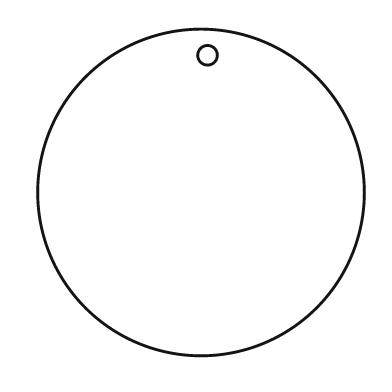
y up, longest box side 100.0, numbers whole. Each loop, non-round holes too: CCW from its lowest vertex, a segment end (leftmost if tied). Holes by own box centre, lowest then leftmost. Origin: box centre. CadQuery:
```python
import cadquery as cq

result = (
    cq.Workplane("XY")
    .moveTo(0.0, 0.0)
    .circle(50.0)
    .moveTo(2.0, 42.0)
    .circle(3.0)
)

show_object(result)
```